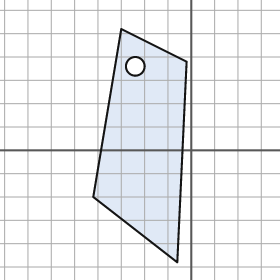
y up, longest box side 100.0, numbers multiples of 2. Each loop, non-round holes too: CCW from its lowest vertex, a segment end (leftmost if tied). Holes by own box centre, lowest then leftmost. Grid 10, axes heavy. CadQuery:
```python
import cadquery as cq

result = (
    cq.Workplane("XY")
    .moveTo(-6.0, -48.0)
    .lineTo(-2.0, 38.0)
    .lineTo(-30.0, 52.0)
    .lineTo(-42.0, -20.0)
    .close()
    .moveTo(-24.0, 36.0)
    .circle(4.0)
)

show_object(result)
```